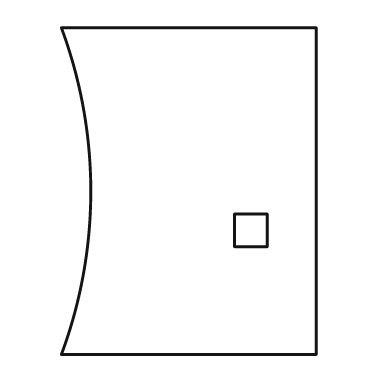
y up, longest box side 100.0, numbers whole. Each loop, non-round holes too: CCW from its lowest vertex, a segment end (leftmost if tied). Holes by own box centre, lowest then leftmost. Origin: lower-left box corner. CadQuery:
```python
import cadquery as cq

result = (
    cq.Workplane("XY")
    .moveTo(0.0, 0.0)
    .lineTo(78.0, 0.0)
    .lineTo(78.0, 100.0)
    .lineTo(0.0, 100.0)
    .threePointArc((9.0, 50.0), (0.0, 0.0))
    .close()
    .moveTo(53.0, 33.0)
    .lineTo(63.0, 33.0)
    .lineTo(63.0, 43.0)
    .lineTo(53.0, 43.0)
    .close()
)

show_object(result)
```